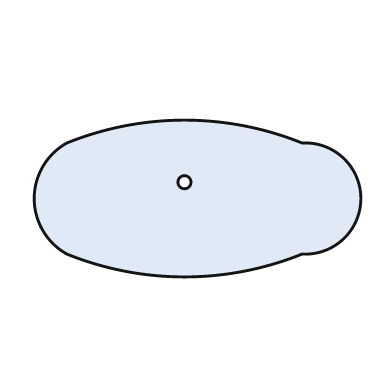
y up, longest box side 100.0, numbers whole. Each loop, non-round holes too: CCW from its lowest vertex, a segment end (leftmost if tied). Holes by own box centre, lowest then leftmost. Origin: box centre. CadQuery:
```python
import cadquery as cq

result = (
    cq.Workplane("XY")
    .moveTo(-40.0, -17.0)
    .threePointArc((-4.0, -24.0), (32.0, -17.0))
    .threePointArc((50.0, 0.0), (32.0, 17.0))
    .threePointArc((-4.0, 24.0), (-40.0, 17.0))
    .threePointArc((-50.0, 0.0), (-40.0, -17.0))
    .close()
    .moveTo(-4.0, 5.0)
    .circle(2.0)
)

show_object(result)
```